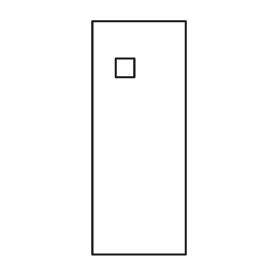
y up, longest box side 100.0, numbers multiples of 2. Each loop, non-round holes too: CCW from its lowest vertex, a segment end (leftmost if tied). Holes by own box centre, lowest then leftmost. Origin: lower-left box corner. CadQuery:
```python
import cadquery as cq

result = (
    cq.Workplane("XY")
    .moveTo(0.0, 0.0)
    .lineTo(40.0, 0.0)
    .lineTo(40.0, 100.0)
    .lineTo(0.0, 100.0)
    .close()
    .moveTo(10.0, 76.0)
    .lineTo(18.0, 76.0)
    .lineTo(18.0, 84.0)
    .lineTo(10.0, 84.0)
    .close()
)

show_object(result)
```